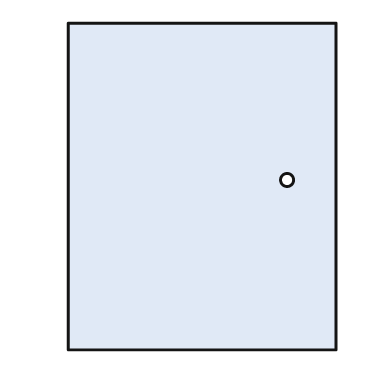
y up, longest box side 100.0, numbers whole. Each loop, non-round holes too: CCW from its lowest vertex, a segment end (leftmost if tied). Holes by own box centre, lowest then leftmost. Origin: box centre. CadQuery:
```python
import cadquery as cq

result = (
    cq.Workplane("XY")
    .moveTo(-41.0, -50.0)
    .lineTo(41.0, -50.0)
    .lineTo(41.0, 50.0)
    .lineTo(-41.0, 50.0)
    .close()
    .moveTo(26.0, 2.0)
    .circle(2.0)
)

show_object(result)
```